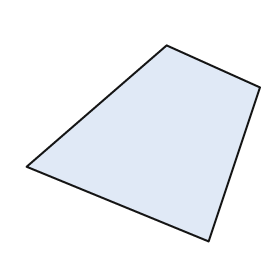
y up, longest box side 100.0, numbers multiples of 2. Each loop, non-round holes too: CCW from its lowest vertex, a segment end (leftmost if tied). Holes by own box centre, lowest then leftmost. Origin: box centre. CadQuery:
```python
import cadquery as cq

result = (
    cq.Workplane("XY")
    .moveTo(28.0, -42.0)
    .lineTo(50.0, 24.0)
    .lineTo(10.0, 42.0)
    .lineTo(-50.0, -10.0)
    .close()
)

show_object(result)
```